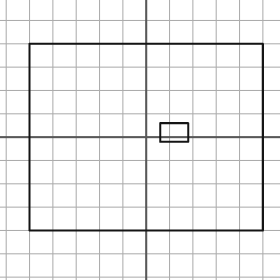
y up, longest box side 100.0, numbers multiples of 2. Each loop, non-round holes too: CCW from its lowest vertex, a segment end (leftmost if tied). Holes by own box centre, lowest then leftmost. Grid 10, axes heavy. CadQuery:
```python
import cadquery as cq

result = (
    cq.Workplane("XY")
    .moveTo(-50.0, -40.0)
    .lineTo(50.0, -40.0)
    .lineTo(50.0, 40.0)
    .lineTo(-50.0, 40.0)
    .close()
    .moveTo(6.0, -2.0)
    .lineTo(18.0, -2.0)
    .lineTo(18.0, 6.0)
    .lineTo(6.0, 6.0)
    .close()
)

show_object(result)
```